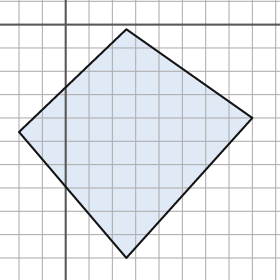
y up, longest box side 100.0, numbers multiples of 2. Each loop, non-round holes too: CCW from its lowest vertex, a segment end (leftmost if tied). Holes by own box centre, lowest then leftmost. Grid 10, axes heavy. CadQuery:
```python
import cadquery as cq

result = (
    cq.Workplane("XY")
    .moveTo(26.0, -100.0)
    .lineTo(80.0, -40.0)
    .lineTo(26.0, -2.0)
    .lineTo(-20.0, -46.0)
    .close()
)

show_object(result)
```